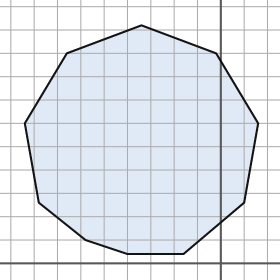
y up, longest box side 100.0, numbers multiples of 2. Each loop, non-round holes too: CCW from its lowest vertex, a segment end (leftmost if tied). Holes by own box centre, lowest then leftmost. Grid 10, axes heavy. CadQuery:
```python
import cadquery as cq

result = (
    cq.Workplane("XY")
    .moveTo(-40.0, 4.0)
    .lineTo(-16.0, 4.0)
    .lineTo(10.0, 26.0)
    .lineTo(16.0, 60.0)
    .lineTo(-2.0, 90.0)
    .lineTo(-34.0, 102.0)
    .lineTo(-66.0, 90.0)
    .lineTo(-84.0, 60.0)
    .lineTo(-78.0, 26.0)
    .lineTo(-58.0, 10.0)
    .close()
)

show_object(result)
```